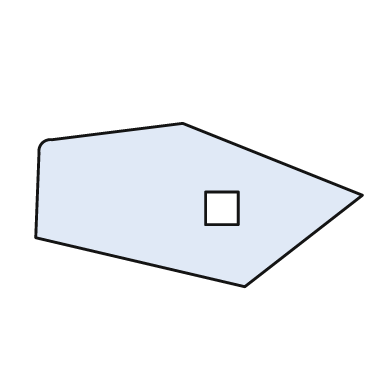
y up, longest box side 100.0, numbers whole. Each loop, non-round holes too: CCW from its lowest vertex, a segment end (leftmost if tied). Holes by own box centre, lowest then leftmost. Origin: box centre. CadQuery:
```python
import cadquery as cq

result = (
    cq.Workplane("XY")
    .moveTo(14.0, -25.0)
    .lineTo(50.0, 3.0)
    .lineTo(-5.0, 25.0)
    .lineTo(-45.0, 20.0)
    .threePointArc((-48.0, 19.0), (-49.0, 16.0))
    .lineTo(-50.0, -10.0)
    .close()
    .moveTo(2.0, -6.0)
    .lineTo(12.0, -6.0)
    .lineTo(12.0, 4.0)
    .lineTo(2.0, 4.0)
    .close()
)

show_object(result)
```